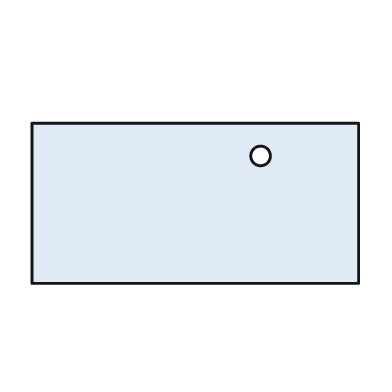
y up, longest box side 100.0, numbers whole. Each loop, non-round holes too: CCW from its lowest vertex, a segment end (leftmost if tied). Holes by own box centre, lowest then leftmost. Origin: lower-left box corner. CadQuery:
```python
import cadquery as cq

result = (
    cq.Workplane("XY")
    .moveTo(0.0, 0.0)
    .lineTo(100.0, 0.0)
    .lineTo(100.0, 49.0)
    .lineTo(0.0, 49.0)
    .close()
    .moveTo(70.0, 39.0)
    .circle(3.0)
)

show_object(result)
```